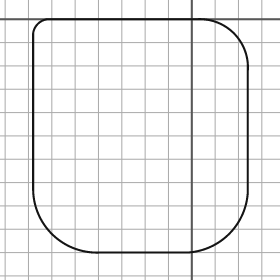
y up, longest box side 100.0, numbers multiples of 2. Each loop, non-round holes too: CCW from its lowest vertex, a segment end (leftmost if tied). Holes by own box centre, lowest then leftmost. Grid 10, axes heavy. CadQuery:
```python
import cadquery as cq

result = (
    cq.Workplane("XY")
    .moveTo(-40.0, -100.0)
    .lineTo(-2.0, -100.0)
    .threePointArc((16.0, -92.0), (24.0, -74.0))
    .lineTo(24.0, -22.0)
    .threePointArc((18.0, -6.0), (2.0, 0.0))
    .lineTo(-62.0, 0.0)
    .threePointArc((-66.0, -2.0), (-68.0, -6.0))
    .lineTo(-68.0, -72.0)
    .threePointArc((-60.0, -92.0), (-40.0, -100.0))
    .close()
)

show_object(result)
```